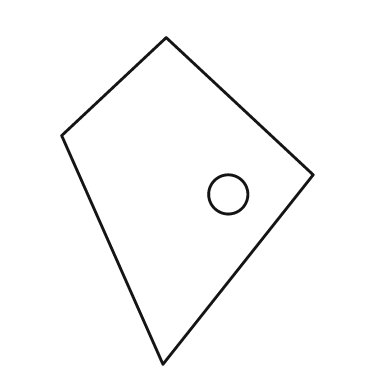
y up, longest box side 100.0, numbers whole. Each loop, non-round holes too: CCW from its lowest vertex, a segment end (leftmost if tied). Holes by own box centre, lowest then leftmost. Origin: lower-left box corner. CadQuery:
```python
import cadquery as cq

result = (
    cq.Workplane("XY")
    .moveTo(31.0, 0.0)
    .lineTo(77.0, 58.0)
    .lineTo(32.0, 100.0)
    .lineTo(0.0, 70.0)
    .close()
    .moveTo(51.0, 52.0)
    .circle(6.0)
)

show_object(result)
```